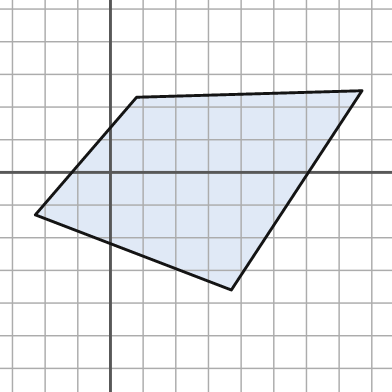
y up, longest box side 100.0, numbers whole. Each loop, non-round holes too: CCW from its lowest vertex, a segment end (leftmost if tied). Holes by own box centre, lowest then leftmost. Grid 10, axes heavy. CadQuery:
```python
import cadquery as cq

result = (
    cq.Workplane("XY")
    .moveTo(37.0, -36.0)
    .lineTo(77.0, 25.0)
    .lineTo(8.0, 23.0)
    .lineTo(-23.0, -13.0)
    .close()
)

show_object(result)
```